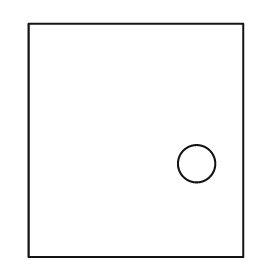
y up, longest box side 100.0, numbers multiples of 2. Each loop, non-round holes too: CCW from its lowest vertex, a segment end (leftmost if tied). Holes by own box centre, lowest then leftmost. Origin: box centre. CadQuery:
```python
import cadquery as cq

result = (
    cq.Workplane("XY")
    .moveTo(-46.0, -50.0)
    .lineTo(46.0, -50.0)
    .lineTo(46.0, 50.0)
    .lineTo(-46.0, 50.0)
    .close()
    .moveTo(26.0, -10.0)
    .circle(8.0)
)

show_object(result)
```